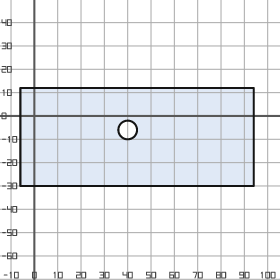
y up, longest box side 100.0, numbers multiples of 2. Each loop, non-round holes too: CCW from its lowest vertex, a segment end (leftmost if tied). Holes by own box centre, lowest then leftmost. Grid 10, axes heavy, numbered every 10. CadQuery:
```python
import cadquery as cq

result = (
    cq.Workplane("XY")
    .moveTo(-6.0, -30.0)
    .lineTo(94.0, -30.0)
    .lineTo(94.0, 12.0)
    .lineTo(-6.0, 12.0)
    .close()
    .moveTo(40.0, -6.0)
    .circle(4.0)
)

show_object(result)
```